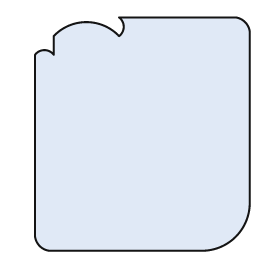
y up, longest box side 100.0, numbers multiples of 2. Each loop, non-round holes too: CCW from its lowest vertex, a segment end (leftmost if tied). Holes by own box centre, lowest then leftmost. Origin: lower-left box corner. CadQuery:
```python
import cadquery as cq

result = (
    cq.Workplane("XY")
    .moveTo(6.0, 0.0)
    .lineTo(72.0, 0.0)
    .threePointArc((86.0, 6.0), (92.0, 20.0))
    .lineTo(92.0, 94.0)
    .threePointArc((90.0, 98.0), (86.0, 100.0))
    .lineTo(36.0, 100.0)
    .threePointArc((38.0, 96.0), (36.0, 92.0))
    .threePointArc((22.0, 98.0), (8.0, 92.0))
    .lineTo(8.0, 84.0)
    .threePointArc((4.0, 86.0), (0.0, 84.0))
    .lineTo(0.0, 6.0)
    .threePointArc((2.0, 2.0), (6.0, 0.0))
    .close()
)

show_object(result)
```